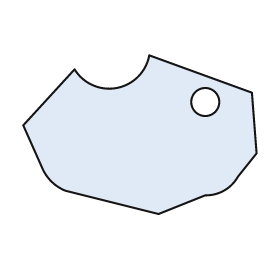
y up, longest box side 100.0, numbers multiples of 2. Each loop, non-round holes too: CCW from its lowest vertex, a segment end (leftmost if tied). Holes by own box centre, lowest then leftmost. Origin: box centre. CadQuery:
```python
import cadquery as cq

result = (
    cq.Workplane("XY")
    .moveTo(8.0, -34.0)
    .lineTo(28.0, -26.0)
    .threePointArc((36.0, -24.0), (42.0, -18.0))
    .lineTo(50.0, -8.0)
    .lineTo(48.0, 18.0)
    .lineTo(4.0, 34.0)
    .threePointArc((-10.0, 20.0), (-28.0, 28.0))
    .lineTo(-50.0, 4.0)
    .lineTo(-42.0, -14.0)
    .threePointArc((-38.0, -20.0), (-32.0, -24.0))
    .close()
    .moveTo(28.0, 14.0)
    .circle(6.0)
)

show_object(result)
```